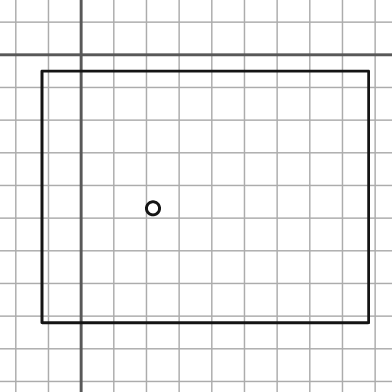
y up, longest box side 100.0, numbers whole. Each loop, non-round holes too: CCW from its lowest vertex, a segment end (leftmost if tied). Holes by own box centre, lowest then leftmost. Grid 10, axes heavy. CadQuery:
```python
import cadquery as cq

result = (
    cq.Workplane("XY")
    .moveTo(-12.0, -82.0)
    .lineTo(88.0, -82.0)
    .lineTo(88.0, -5.0)
    .lineTo(-12.0, -5.0)
    .close()
    .moveTo(22.0, -47.0)
    .circle(2.0)
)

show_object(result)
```